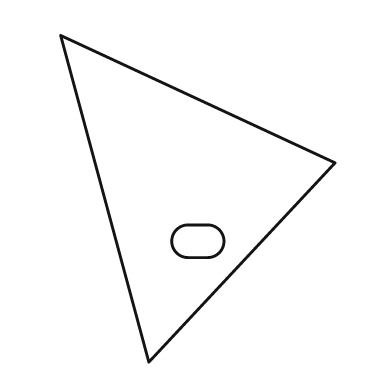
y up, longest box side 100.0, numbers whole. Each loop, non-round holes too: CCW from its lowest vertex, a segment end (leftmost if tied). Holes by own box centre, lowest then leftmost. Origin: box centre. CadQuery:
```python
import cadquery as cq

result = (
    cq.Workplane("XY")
    .moveTo(-15.0, -50.0)
    .lineTo(42.0, 11.0)
    .lineTo(-42.0, 50.0)
    .close()
    .moveTo(-3.0, -18.0)
    .lineTo(3.0, -18.0)
    .threePointArc((8.0, -13.0), (3.0, -8.0))
    .lineTo(-3.0, -8.0)
    .threePointArc((-8.0, -13.0), (-3.0, -18.0))
    .close()
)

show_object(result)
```